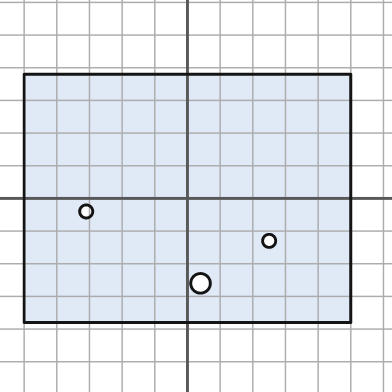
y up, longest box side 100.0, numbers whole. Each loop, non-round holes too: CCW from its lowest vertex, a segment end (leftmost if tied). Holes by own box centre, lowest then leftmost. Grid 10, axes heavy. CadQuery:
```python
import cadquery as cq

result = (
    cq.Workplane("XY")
    .moveTo(-50.0, -38.0)
    .lineTo(50.0, -38.0)
    .lineTo(50.0, 38.0)
    .lineTo(-50.0, 38.0)
    .close()
    .moveTo(4.0, -26.0)
    .circle(3.0)
    .moveTo(25.0, -13.0)
    .circle(2.0)
    .moveTo(-31.0, -4.0)
    .circle(2.0)
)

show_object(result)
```